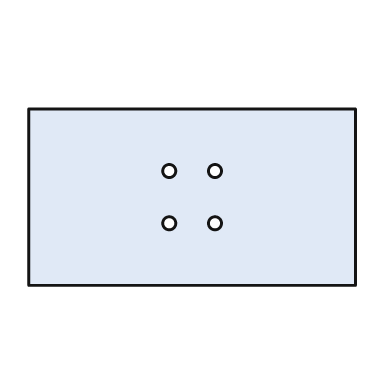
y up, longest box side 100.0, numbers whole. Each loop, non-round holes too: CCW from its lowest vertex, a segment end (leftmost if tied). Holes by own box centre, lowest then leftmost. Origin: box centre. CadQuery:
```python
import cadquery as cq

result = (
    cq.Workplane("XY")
    .moveTo(-50.0, -27.0)
    .lineTo(50.0, -27.0)
    .lineTo(50.0, 27.0)
    .lineTo(-50.0, 27.0)
    .close()
    .moveTo(-7.0, -8.0)
    .circle(2.0)
    .moveTo(7.0, -8.0)
    .circle(2.0)
    .moveTo(-7.0, 8.0)
    .circle(2.0)
    .moveTo(7.0, 8.0)
    .circle(2.0)
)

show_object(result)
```